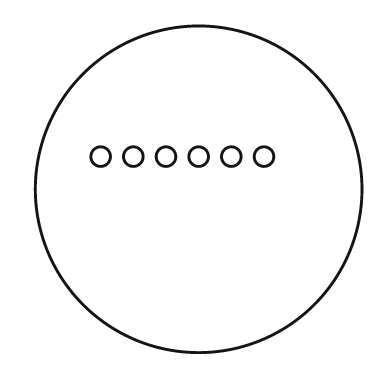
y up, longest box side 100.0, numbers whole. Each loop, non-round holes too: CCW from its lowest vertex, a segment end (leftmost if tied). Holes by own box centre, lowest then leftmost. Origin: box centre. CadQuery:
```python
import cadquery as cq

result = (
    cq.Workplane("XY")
    .moveTo(0.0, 0.0)
    .circle(50.0)
    .moveTo(-30.0, 10.0)
    .circle(3.0)
    .moveTo(-20.0, 10.0)
    .circle(3.0)
    .moveTo(-10.0, 10.0)
    .circle(3.0)
    .moveTo(0.0, 10.0)
    .circle(3.0)
    .moveTo(10.0, 10.0)
    .circle(3.0)
    .moveTo(20.0, 10.0)
    .circle(3.0)
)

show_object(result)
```